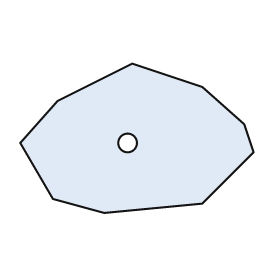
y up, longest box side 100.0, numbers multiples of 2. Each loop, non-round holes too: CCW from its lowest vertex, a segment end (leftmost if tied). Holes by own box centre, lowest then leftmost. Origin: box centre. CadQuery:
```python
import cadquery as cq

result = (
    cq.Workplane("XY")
    .moveTo(-14.0, -32.0)
    .lineTo(28.0, -28.0)
    .lineTo(50.0, -6.0)
    .lineTo(46.0, 6.0)
    .lineTo(28.0, 22.0)
    .lineTo(-2.0, 32.0)
    .lineTo(-34.0, 16.0)
    .lineTo(-50.0, -2.0)
    .lineTo(-36.0, -26.0)
    .close()
    .moveTo(-4.0, -2.0)
    .circle(4.0)
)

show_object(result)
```